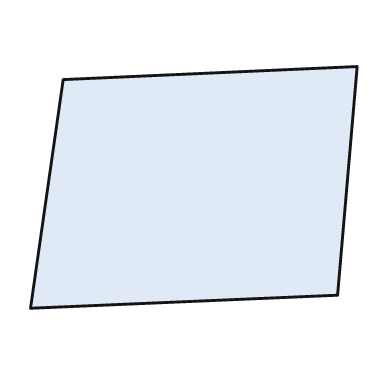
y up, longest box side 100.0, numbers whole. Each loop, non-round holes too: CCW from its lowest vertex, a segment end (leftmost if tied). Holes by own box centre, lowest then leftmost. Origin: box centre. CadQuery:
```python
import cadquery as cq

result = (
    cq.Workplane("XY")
    .moveTo(-50.0, -37.0)
    .lineTo(44.0, -33.0)
    .lineTo(50.0, 37.0)
    .lineTo(-40.0, 33.0)
    .close()
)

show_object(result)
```